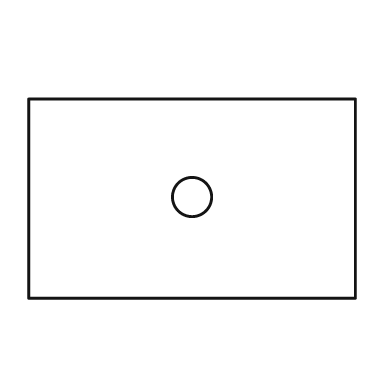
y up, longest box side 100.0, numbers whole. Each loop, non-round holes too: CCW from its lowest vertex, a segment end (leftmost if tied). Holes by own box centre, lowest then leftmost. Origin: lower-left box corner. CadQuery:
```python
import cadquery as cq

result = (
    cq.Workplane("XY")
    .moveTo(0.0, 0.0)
    .lineTo(100.0, 0.0)
    .lineTo(100.0, 61.0)
    .lineTo(0.0, 61.0)
    .close()
    .moveTo(50.0, 31.0)
    .circle(6.0)
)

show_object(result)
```